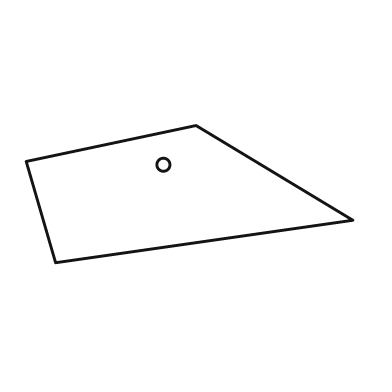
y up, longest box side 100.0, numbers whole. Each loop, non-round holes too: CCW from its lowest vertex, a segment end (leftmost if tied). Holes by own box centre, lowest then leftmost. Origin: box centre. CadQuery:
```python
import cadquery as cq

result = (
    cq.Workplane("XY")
    .moveTo(-41.0, -21.0)
    .lineTo(50.0, -8.0)
    .lineTo(2.0, 21.0)
    .lineTo(-50.0, 10.0)
    .close()
    .moveTo(-8.0, 9.0)
    .circle(2.0)
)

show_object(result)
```